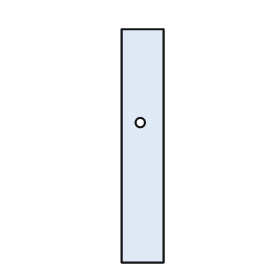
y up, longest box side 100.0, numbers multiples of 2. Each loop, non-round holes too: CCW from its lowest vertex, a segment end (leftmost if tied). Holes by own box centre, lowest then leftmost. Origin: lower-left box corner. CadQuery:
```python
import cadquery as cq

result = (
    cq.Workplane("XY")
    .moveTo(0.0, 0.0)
    .lineTo(18.0, 0.0)
    .lineTo(18.0, 100.0)
    .lineTo(0.0, 100.0)
    .close()
    .moveTo(8.0, 60.0)
    .circle(2.0)
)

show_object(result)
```